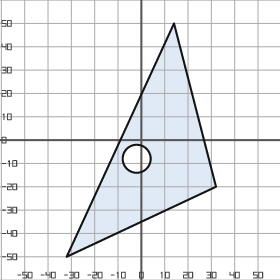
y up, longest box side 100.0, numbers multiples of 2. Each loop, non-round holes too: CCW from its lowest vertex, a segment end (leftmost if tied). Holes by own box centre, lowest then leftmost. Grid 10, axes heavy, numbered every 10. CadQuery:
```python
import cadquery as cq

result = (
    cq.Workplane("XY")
    .moveTo(-32.0, -50.0)
    .lineTo(32.0, -20.0)
    .lineTo(14.0, 50.0)
    .close()
    .moveTo(-2.0, -8.0)
    .circle(6.0)
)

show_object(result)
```